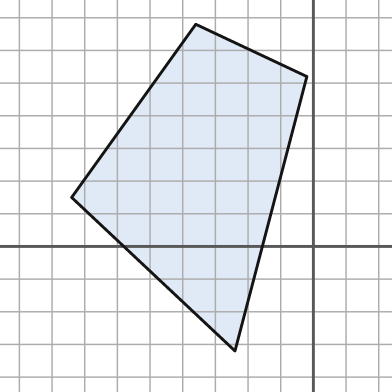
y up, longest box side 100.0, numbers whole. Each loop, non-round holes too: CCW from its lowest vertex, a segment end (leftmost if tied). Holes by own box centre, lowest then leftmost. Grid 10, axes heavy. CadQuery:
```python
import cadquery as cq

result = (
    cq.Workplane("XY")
    .moveTo(-24.0, -32.0)
    .lineTo(-2.0, 52.0)
    .lineTo(-36.0, 68.0)
    .lineTo(-74.0, 15.0)
    .close()
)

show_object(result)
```